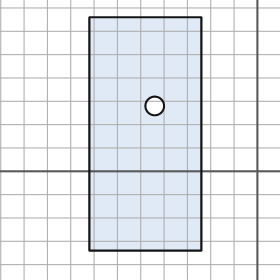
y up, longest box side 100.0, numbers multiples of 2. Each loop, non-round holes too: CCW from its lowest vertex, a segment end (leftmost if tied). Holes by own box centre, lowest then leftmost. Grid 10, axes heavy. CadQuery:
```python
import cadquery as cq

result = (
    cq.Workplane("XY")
    .moveTo(-72.0, -34.0)
    .lineTo(-24.0, -34.0)
    .lineTo(-24.0, 66.0)
    .lineTo(-72.0, 66.0)
    .close()
    .moveTo(-44.0, 28.0)
    .circle(4.0)
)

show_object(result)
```